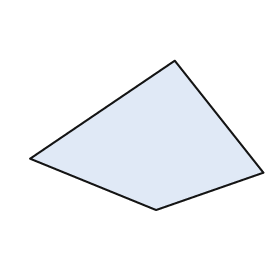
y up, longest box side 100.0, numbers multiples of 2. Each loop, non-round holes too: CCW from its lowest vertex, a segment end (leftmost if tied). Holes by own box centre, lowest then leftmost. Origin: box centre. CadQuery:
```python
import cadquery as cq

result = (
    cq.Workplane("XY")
    .moveTo(4.0, -32.0)
    .lineTo(50.0, -16.0)
    .lineTo(12.0, 32.0)
    .lineTo(-50.0, -10.0)
    .close()
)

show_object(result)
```